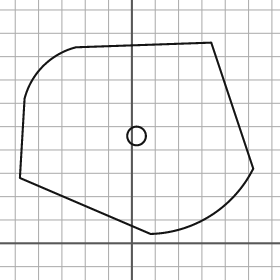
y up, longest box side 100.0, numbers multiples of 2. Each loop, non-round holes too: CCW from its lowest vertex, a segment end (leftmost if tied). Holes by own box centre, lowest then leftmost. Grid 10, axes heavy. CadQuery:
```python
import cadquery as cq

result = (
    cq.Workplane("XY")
    .moveTo(8.0, 4.0)
    .threePointArc((34.0, 12.0), (52.0, 32.0))
    .lineTo(34.0, 86.0)
    .lineTo(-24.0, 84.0)
    .threePointArc((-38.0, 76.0), (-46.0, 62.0))
    .lineTo(-48.0, 28.0)
    .close()
    .moveTo(2.0, 46.0)
    .circle(4.0)
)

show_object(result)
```